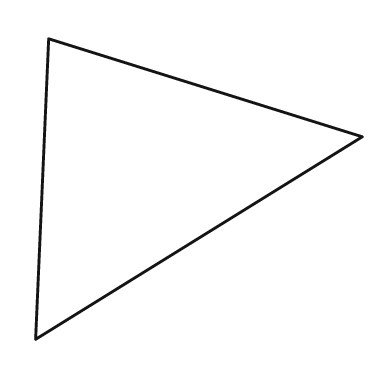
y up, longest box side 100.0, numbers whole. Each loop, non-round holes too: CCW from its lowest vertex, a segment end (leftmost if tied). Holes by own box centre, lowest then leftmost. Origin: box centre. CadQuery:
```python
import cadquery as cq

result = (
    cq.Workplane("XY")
    .moveTo(-50.0, -46.0)
    .lineTo(50.0, 16.0)
    .lineTo(-46.0, 46.0)
    .close()
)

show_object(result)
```